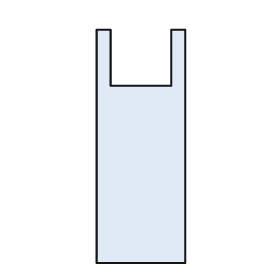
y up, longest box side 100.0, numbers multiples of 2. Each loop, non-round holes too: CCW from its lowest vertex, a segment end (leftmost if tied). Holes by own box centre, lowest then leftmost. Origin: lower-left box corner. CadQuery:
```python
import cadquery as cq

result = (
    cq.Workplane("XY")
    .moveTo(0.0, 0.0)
    .lineTo(38.0, 0.0)
    .lineTo(38.0, 100.0)
    .lineTo(32.0, 100.0)
    .lineTo(32.0, 76.0)
    .lineTo(6.0, 76.0)
    .lineTo(6.0, 100.0)
    .lineTo(0.0, 100.0)
    .close()
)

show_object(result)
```